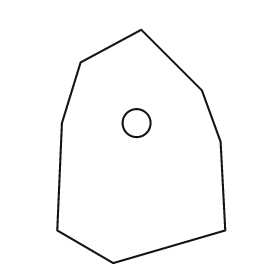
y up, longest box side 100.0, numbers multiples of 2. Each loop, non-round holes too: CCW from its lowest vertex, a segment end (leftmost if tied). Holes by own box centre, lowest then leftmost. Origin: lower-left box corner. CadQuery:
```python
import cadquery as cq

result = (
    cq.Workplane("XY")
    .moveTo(24.0, 0.0)
    .lineTo(72.0, 14.0)
    .lineTo(70.0, 52.0)
    .lineTo(62.0, 74.0)
    .lineTo(36.0, 100.0)
    .lineTo(10.0, 86.0)
    .lineTo(2.0, 60.0)
    .lineTo(0.0, 14.0)
    .close()
    .moveTo(34.0, 60.0)
    .circle(6.0)
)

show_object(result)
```